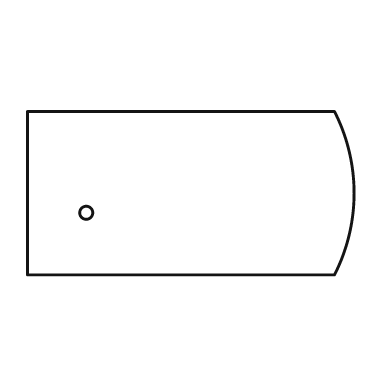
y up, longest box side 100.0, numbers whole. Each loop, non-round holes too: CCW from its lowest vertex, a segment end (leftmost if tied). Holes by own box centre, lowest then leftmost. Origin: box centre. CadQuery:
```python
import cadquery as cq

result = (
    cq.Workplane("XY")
    .moveTo(-50.0, -25.0)
    .lineTo(44.0, -25.0)
    .threePointArc((50.0, 0.0), (44.0, 25.0))
    .lineTo(-50.0, 25.0)
    .close()
    .moveTo(-32.0, -6.0)
    .circle(2.0)
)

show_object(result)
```